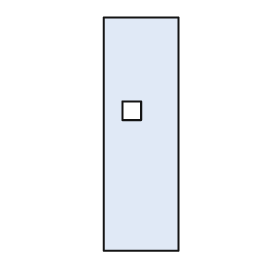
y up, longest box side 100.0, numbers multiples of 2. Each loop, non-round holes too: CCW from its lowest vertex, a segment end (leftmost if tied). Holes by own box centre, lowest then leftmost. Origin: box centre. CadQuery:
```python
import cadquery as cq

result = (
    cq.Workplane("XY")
    .moveTo(-16.0, -50.0)
    .lineTo(16.0, -50.0)
    .lineTo(16.0, 50.0)
    .lineTo(-16.0, 50.0)
    .close()
    .moveTo(-8.0, 6.0)
    .lineTo(0.0, 6.0)
    .lineTo(0.0, 14.0)
    .lineTo(-8.0, 14.0)
    .close()
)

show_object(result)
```